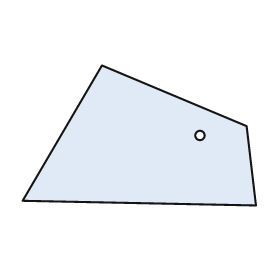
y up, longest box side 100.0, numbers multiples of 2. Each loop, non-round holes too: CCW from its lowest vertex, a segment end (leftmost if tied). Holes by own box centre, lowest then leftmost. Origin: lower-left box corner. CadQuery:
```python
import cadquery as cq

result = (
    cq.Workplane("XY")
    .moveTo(100.0, 0.0)
    .lineTo(96.0, 34.0)
    .lineTo(34.0, 60.0)
    .lineTo(0.0, 2.0)
    .close()
    .moveTo(76.0, 30.0)
    .circle(2.0)
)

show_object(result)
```